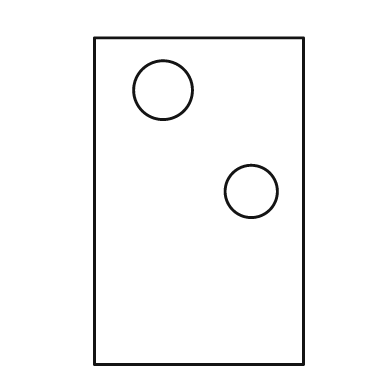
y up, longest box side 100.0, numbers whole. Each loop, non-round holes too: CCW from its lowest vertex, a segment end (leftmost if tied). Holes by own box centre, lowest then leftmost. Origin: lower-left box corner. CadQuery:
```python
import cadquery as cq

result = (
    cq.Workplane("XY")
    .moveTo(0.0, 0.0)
    .lineTo(64.0, 0.0)
    .lineTo(64.0, 100.0)
    .lineTo(0.0, 100.0)
    .close()
    .moveTo(48.0, 53.0)
    .circle(8.0)
    .moveTo(21.0, 84.0)
    .circle(9.0)
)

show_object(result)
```